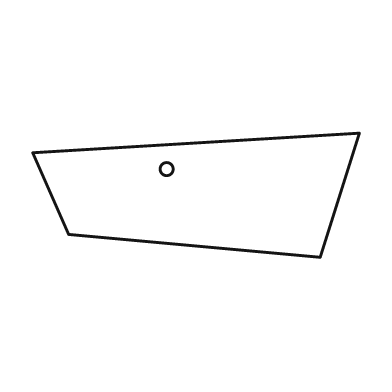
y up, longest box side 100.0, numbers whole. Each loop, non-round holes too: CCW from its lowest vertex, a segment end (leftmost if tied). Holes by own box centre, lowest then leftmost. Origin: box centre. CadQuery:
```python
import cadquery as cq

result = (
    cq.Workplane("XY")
    .moveTo(38.0, -19.0)
    .lineTo(50.0, 19.0)
    .lineTo(-50.0, 13.0)
    .lineTo(-39.0, -12.0)
    .close()
    .moveTo(-9.0, 8.0)
    .circle(2.0)
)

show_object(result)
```